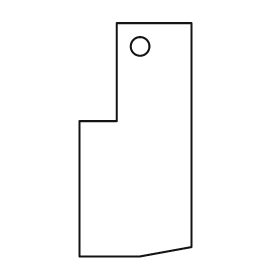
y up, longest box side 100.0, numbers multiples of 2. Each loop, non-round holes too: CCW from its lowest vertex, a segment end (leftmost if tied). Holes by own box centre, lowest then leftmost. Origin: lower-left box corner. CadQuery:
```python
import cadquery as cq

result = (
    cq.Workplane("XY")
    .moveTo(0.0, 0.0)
    .lineTo(26.0, 0.0)
    .lineTo(48.0, 4.0)
    .lineTo(48.0, 100.0)
    .lineTo(16.0, 100.0)
    .lineTo(16.0, 58.0)
    .lineTo(0.0, 58.0)
    .close()
    .moveTo(26.0, 90.0)
    .circle(4.0)
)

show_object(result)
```